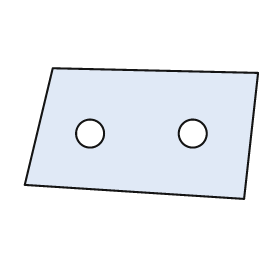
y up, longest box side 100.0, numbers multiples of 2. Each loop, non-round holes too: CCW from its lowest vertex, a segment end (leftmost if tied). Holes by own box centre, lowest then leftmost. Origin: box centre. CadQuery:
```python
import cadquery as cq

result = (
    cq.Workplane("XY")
    .moveTo(44.0, -28.0)
    .lineTo(50.0, 26.0)
    .lineTo(-38.0, 28.0)
    .lineTo(-50.0, -22.0)
    .close()
    .moveTo(-22.0, 0.0)
    .circle(6.0)
    .moveTo(22.0, 0.0)
    .circle(6.0)
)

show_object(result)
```